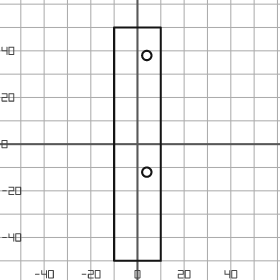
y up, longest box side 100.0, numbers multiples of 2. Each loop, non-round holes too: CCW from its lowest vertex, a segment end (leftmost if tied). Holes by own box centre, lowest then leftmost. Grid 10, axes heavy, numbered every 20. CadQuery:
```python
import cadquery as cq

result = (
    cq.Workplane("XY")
    .moveTo(-10.0, -50.0)
    .lineTo(10.0, -50.0)
    .lineTo(10.0, 50.0)
    .lineTo(-10.0, 50.0)
    .close()
    .moveTo(4.0, -12.0)
    .circle(2.0)
    .moveTo(4.0, 38.0)
    .circle(2.0)
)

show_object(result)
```